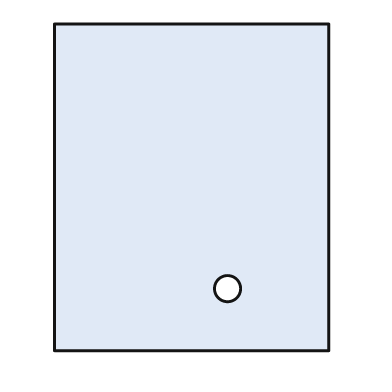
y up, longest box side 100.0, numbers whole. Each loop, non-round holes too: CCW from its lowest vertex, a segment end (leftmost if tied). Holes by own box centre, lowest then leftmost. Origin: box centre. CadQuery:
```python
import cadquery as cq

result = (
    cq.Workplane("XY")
    .moveTo(-42.0, -50.0)
    .lineTo(42.0, -50.0)
    .lineTo(42.0, 50.0)
    .lineTo(-42.0, 50.0)
    .close()
    .moveTo(11.0, -31.0)
    .circle(4.0)
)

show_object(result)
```